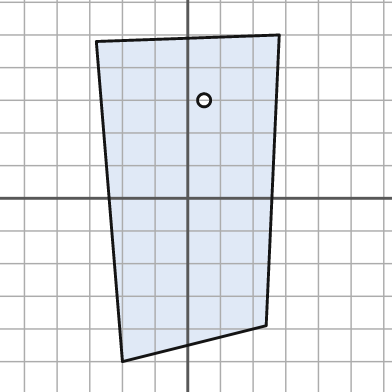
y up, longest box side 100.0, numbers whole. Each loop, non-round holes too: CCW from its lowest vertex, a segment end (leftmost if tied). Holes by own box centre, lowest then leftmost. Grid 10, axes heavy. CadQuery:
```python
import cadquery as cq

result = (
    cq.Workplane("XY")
    .moveTo(-20.0, -50.0)
    .lineTo(24.0, -39.0)
    .lineTo(28.0, 50.0)
    .lineTo(-28.0, 48.0)
    .close()
    .moveTo(5.0, 30.0)
    .circle(2.0)
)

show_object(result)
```